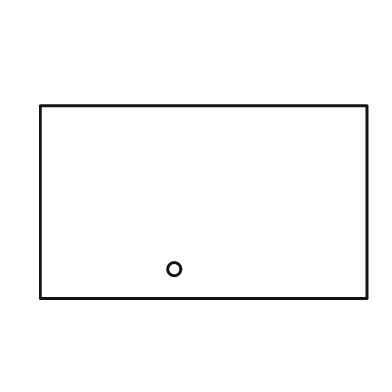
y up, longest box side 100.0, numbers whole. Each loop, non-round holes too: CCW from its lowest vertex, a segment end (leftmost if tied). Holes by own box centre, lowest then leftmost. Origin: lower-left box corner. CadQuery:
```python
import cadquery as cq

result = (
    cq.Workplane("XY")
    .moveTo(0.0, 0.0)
    .lineTo(100.0, 0.0)
    .lineTo(100.0, 59.0)
    .lineTo(0.0, 59.0)
    .close()
    .moveTo(41.0, 9.0)
    .circle(2.0)
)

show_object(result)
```